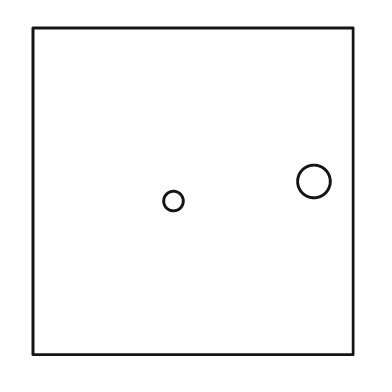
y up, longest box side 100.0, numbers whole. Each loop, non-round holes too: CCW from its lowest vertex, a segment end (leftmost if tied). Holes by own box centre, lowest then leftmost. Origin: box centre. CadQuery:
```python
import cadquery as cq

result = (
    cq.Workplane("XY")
    .moveTo(-49.0, -50.0)
    .lineTo(49.0, -50.0)
    .lineTo(49.0, 50.0)
    .lineTo(-49.0, 50.0)
    .close()
    .moveTo(-6.0, -3.0)
    .circle(3.0)
    .moveTo(37.0, 3.0)
    .circle(5.0)
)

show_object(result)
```